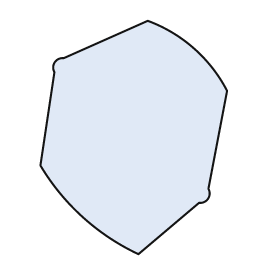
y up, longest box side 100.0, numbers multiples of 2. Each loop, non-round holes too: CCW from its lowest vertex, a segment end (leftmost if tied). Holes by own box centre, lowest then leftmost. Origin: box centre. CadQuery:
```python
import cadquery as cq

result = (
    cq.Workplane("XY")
    .moveTo(2.0, -50.0)
    .lineTo(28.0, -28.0)
    .threePointArc((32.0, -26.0), (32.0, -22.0))
    .lineTo(40.0, 20.0)
    .threePointArc((26.0, 38.0), (6.0, 50.0))
    .lineTo(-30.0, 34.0)
    .threePointArc((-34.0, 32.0), (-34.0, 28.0))
    .lineTo(-40.0, -12.0)
    .threePointArc((-22.0, -34.0), (2.0, -50.0))
    .close()
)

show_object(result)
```